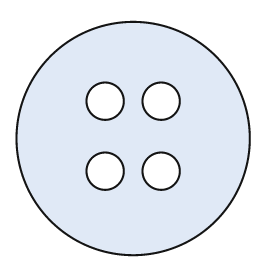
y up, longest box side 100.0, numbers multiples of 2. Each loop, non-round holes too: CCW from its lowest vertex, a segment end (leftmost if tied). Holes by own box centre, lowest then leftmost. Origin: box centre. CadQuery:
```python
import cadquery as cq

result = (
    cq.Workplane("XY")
    .moveTo(0.0, 0.0)
    .circle(50.0)
    .moveTo(-12.0, -14.0)
    .circle(8.0)
    .moveTo(12.0, -14.0)
    .circle(8.0)
    .moveTo(-12.0, 16.0)
    .circle(8.0)
    .moveTo(12.0, 16.0)
    .circle(8.0)
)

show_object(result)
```